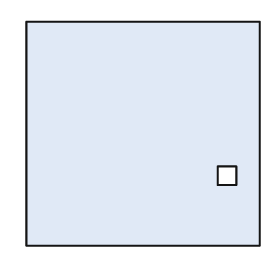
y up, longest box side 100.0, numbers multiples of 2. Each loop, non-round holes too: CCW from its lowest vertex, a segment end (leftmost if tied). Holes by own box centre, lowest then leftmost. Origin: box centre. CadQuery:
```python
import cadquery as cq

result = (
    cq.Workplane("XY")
    .moveTo(-50.0, -48.0)
    .lineTo(50.0, -48.0)
    .lineTo(50.0, 48.0)
    .lineTo(-50.0, 48.0)
    .close()
    .moveTo(32.0, -22.0)
    .lineTo(40.0, -22.0)
    .lineTo(40.0, -14.0)
    .lineTo(32.0, -14.0)
    .close()
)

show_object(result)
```